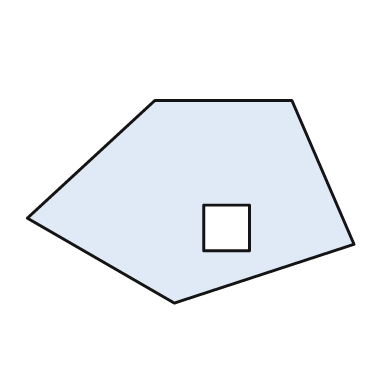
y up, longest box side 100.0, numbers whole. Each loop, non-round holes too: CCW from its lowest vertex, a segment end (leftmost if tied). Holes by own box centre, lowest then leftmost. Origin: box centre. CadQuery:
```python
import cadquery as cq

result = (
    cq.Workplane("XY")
    .moveTo(-5.0, -31.0)
    .lineTo(50.0, -13.0)
    .lineTo(31.0, 31.0)
    .lineTo(-11.0, 31.0)
    .lineTo(-50.0, -5.0)
    .close()
    .moveTo(4.0, -15.0)
    .lineTo(18.0, -15.0)
    .lineTo(18.0, -1.0)
    .lineTo(4.0, -1.0)
    .close()
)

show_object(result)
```